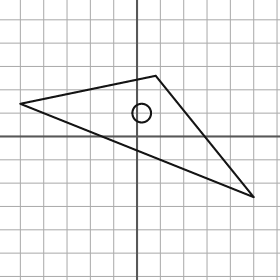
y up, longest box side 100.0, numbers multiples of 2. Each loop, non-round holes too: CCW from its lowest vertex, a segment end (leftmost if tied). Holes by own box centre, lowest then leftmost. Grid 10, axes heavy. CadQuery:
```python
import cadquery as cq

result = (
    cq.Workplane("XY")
    .moveTo(50.0, -26.0)
    .lineTo(8.0, 26.0)
    .lineTo(-50.0, 14.0)
    .close()
    .moveTo(2.0, 10.0)
    .circle(4.0)
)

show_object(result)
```